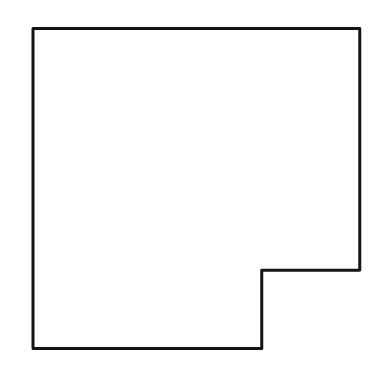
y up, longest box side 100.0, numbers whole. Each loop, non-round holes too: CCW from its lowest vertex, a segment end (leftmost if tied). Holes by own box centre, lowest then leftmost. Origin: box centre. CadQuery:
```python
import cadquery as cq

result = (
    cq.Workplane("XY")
    .moveTo(-50.0, -49.0)
    .lineTo(20.0, -49.0)
    .lineTo(20.0, -25.0)
    .lineTo(50.0, -25.0)
    .lineTo(50.0, 49.0)
    .lineTo(-50.0, 49.0)
    .close()
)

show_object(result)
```